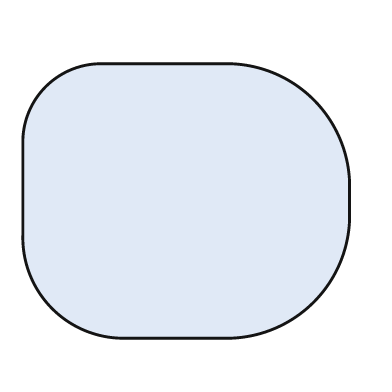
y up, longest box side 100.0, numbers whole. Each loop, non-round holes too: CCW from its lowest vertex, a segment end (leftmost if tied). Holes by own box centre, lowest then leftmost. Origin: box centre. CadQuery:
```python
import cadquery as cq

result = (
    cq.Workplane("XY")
    .moveTo(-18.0, -42.0)
    .lineTo(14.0, -42.0)
    .threePointArc((39.0, -31.0), (50.0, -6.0))
    .lineTo(50.0, 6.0)
    .threePointArc((39.0, 31.0), (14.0, 42.0))
    .lineTo(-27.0, 42.0)
    .threePointArc((-43.0, 35.0), (-50.0, 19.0))
    .lineTo(-50.0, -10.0)
    .threePointArc((-41.0, -33.0), (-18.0, -42.0))
    .close()
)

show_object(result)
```